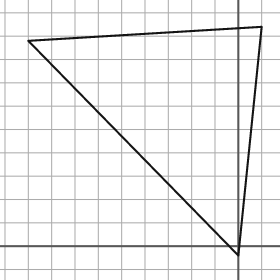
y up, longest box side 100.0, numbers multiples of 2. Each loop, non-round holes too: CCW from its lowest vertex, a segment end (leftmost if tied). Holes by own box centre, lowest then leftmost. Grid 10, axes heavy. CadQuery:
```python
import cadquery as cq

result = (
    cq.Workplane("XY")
    .moveTo(0.0, -4.0)
    .lineTo(10.0, 94.0)
    .lineTo(-90.0, 88.0)
    .close()
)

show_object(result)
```